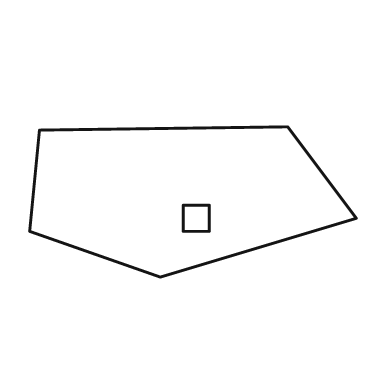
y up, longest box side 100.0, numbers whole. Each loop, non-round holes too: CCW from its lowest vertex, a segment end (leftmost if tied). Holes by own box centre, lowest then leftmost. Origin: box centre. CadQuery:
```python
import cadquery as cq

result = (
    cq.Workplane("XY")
    .moveTo(-10.0, -23.0)
    .lineTo(50.0, -5.0)
    .lineTo(29.0, 23.0)
    .lineTo(-47.0, 22.0)
    .lineTo(-50.0, -9.0)
    .close()
    .moveTo(-3.0, -9.0)
    .lineTo(5.0, -9.0)
    .lineTo(5.0, -1.0)
    .lineTo(-3.0, -1.0)
    .close()
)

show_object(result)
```